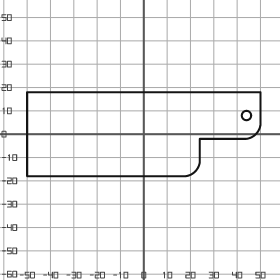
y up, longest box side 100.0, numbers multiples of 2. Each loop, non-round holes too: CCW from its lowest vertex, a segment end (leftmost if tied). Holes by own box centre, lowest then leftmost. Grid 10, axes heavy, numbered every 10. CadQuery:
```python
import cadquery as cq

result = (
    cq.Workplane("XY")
    .moveTo(-50.0, -18.0)
    .lineTo(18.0, -18.0)
    .threePointArc((22.0, -16.0), (24.0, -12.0))
    .lineTo(24.0, -2.0)
    .lineTo(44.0, -2.0)
    .threePointArc((48.0, 0.0), (50.0, 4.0))
    .lineTo(50.0, 18.0)
    .lineTo(-50.0, 18.0)
    .close()
    .moveTo(44.0, 8.0)
    .circle(2.0)
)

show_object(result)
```